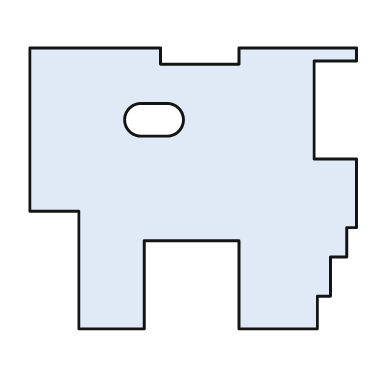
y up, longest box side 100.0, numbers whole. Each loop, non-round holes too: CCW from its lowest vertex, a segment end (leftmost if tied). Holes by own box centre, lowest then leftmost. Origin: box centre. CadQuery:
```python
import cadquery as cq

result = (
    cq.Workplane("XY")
    .moveTo(-35.0, -43.0)
    .lineTo(-15.0, -43.0)
    .lineTo(-15.0, -16.0)
    .lineTo(14.0, -16.0)
    .lineTo(14.0, -43.0)
    .lineTo(38.0, -43.0)
    .lineTo(38.0, -33.0)
    .lineTo(42.0, -33.0)
    .lineTo(42.0, -21.0)
    .lineTo(47.0, -21.0)
    .lineTo(47.0, -12.0)
    .lineTo(50.0, -12.0)
    .lineTo(50.0, 9.0)
    .lineTo(37.0, 9.0)
    .lineTo(37.0, 39.0)
    .lineTo(50.0, 39.0)
    .lineTo(50.0, 43.0)
    .lineTo(14.0, 43.0)
    .lineTo(14.0, 38.0)
    .lineTo(-10.0, 38.0)
    .lineTo(-10.0, 43.0)
    .lineTo(-50.0, 43.0)
    .lineTo(-50.0, -7.0)
    .lineTo(-35.0, -7.0)
    .close()
    .moveTo(-16.0, 16.0)
    .lineTo(-8.0, 16.0)
    .threePointArc((-3.0, 21.0), (-8.0, 26.0))
    .lineTo(-16.0, 26.0)
    .threePointArc((-21.0, 21.0), (-16.0, 16.0))
    .close()
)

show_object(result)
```